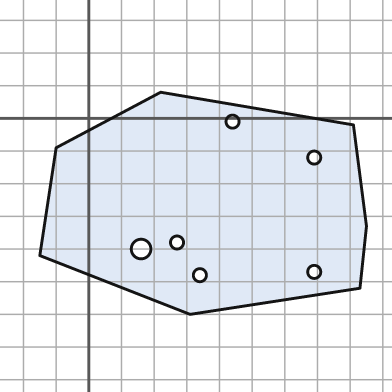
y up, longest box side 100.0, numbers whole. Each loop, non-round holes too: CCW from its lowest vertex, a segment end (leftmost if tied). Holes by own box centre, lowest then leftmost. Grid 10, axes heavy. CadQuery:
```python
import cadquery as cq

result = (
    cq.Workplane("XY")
    .moveTo(31.0, -60.0)
    .lineTo(83.0, -52.0)
    .lineTo(85.0, -33.0)
    .lineTo(81.0, -2.0)
    .lineTo(22.0, 8.0)
    .lineTo(-10.0, -9.0)
    .lineTo(-15.0, -42.0)
    .close()
    .moveTo(34.0, -48.0)
    .circle(2.0)
    .moveTo(69.0, -47.0)
    .circle(2.0)
    .moveTo(16.0, -40.0)
    .circle(3.0)
    .moveTo(27.0, -38.0)
    .circle(2.0)
    .moveTo(69.0, -12.0)
    .circle(2.0)
    .moveTo(44.0, -1.0)
    .circle(2.0)
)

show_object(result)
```